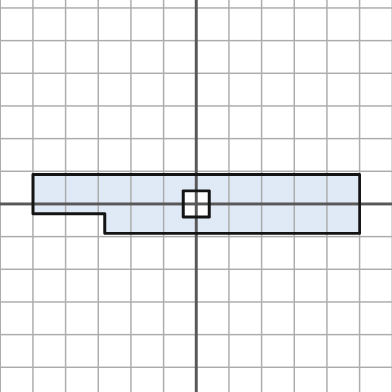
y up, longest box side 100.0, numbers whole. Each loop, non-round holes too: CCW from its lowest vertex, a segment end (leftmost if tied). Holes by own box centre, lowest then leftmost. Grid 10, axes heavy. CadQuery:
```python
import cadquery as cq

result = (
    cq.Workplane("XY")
    .moveTo(-28.0, -9.0)
    .lineTo(50.0, -9.0)
    .lineTo(50.0, 9.0)
    .lineTo(-50.0, 9.0)
    .lineTo(-50.0, -3.0)
    .lineTo(-28.0, -3.0)
    .close()
    .moveTo(-4.0, -4.0)
    .lineTo(4.0, -4.0)
    .lineTo(4.0, 4.0)
    .lineTo(-4.0, 4.0)
    .close()
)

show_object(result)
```